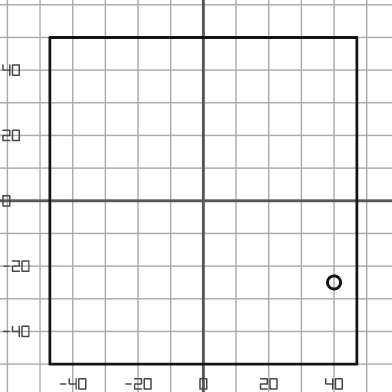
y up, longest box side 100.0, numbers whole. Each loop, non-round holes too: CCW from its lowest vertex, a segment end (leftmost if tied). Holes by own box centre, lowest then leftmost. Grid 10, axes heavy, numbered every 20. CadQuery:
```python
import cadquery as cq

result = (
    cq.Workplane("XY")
    .moveTo(-47.0, -50.0)
    .lineTo(47.0, -50.0)
    .lineTo(47.0, 50.0)
    .lineTo(-47.0, 50.0)
    .close()
    .moveTo(40.0, -25.0)
    .circle(2.0)
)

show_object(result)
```